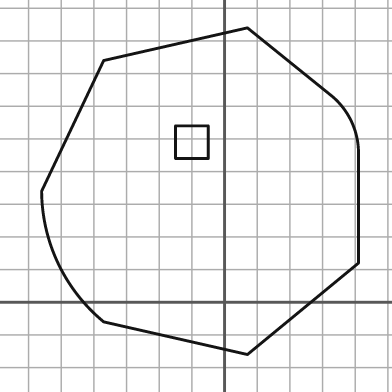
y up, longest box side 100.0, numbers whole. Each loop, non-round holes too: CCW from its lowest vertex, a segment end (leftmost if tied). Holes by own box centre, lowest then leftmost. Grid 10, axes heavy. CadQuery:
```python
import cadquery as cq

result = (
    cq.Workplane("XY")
    .moveTo(7.0, -16.0)
    .lineTo(41.0, 12.0)
    .lineTo(41.0, 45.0)
    .threePointArc((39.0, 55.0), (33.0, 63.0))
    .lineTo(7.0, 84.0)
    .lineTo(-37.0, 74.0)
    .lineTo(-56.0, 34.0)
    .threePointArc((-51.0, 12.0), (-37.0, -6.0))
    .close()
    .moveTo(-15.0, 44.0)
    .lineTo(-5.0, 44.0)
    .lineTo(-5.0, 54.0)
    .lineTo(-15.0, 54.0)
    .close()
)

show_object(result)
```